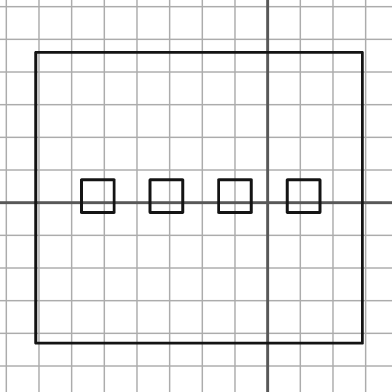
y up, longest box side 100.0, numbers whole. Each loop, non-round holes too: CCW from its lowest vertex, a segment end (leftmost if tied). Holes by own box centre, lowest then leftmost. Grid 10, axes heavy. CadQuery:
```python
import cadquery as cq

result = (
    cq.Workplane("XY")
    .moveTo(-71.0, -43.0)
    .lineTo(29.0, -43.0)
    .lineTo(29.0, 46.0)
    .lineTo(-71.0, 46.0)
    .close()
    .moveTo(-57.0, -3.0)
    .lineTo(-47.0, -3.0)
    .lineTo(-47.0, 7.0)
    .lineTo(-57.0, 7.0)
    .close()
    .moveTo(-36.0, -3.0)
    .lineTo(-26.0, -3.0)
    .lineTo(-26.0, 7.0)
    .lineTo(-36.0, 7.0)
    .close()
    .moveTo(-15.0, -3.0)
    .lineTo(-5.0, -3.0)
    .lineTo(-5.0, 7.0)
    .lineTo(-15.0, 7.0)
    .close()
    .moveTo(6.0, -3.0)
    .lineTo(16.0, -3.0)
    .lineTo(16.0, 7.0)
    .lineTo(6.0, 7.0)
    .close()
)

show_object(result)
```